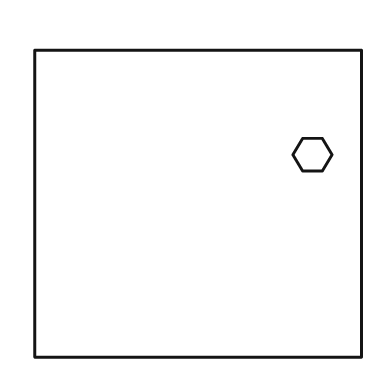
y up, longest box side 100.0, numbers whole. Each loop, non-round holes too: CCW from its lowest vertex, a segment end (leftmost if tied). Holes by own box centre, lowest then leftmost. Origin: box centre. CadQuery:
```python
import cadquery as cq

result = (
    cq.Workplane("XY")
    .moveTo(-50.0, -47.0)
    .lineTo(50.0, -47.0)
    .lineTo(50.0, 47.0)
    .lineTo(-50.0, 47.0)
    .close()
    .moveTo(32.0, 10.0)
    .lineTo(38.0, 10.0)
    .lineTo(41.0, 15.0)
    .lineTo(38.0, 20.0)
    .lineTo(32.0, 20.0)
    .lineTo(29.0, 15.0)
    .close()
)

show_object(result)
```